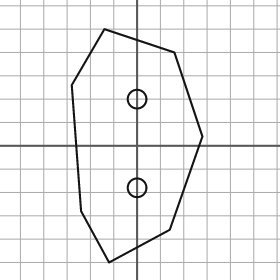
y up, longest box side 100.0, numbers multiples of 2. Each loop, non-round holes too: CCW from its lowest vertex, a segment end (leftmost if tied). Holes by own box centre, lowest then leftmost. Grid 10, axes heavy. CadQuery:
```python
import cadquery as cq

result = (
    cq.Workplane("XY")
    .moveTo(-12.0, -50.0)
    .lineTo(14.0, -36.0)
    .lineTo(28.0, 4.0)
    .lineTo(16.0, 40.0)
    .lineTo(-14.0, 50.0)
    .lineTo(-28.0, 26.0)
    .lineTo(-24.0, -28.0)
    .close()
    .moveTo(0.0, -18.0)
    .circle(4.0)
    .moveTo(0.0, 20.0)
    .circle(4.0)
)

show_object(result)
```